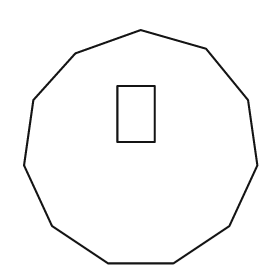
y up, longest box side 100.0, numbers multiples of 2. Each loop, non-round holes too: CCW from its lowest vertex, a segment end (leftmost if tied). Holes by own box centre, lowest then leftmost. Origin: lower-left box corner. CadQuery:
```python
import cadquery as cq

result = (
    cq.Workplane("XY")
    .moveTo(36.0, 0.0)
    .lineTo(64.0, 0.0)
    .lineTo(88.0, 16.0)
    .lineTo(100.0, 42.0)
    .lineTo(96.0, 70.0)
    .lineTo(78.0, 92.0)
    .lineTo(50.0, 100.0)
    .lineTo(22.0, 90.0)
    .lineTo(4.0, 70.0)
    .lineTo(0.0, 42.0)
    .lineTo(12.0, 16.0)
    .close()
    .moveTo(40.0, 52.0)
    .lineTo(56.0, 52.0)
    .lineTo(56.0, 76.0)
    .lineTo(40.0, 76.0)
    .close()
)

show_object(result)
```